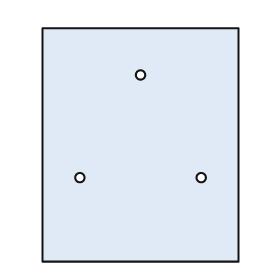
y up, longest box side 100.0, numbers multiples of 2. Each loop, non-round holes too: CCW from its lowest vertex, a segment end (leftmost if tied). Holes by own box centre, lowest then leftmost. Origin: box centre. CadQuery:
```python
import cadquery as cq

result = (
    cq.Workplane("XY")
    .moveTo(-42.0, -50.0)
    .lineTo(42.0, -50.0)
    .lineTo(42.0, 50.0)
    .lineTo(-42.0, 50.0)
    .close()
    .moveTo(-26.0, -14.0)
    .circle(2.0)
    .moveTo(26.0, -14.0)
    .circle(2.0)
    .moveTo(0.0, 30.0)
    .circle(2.0)
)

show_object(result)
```